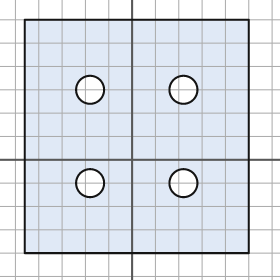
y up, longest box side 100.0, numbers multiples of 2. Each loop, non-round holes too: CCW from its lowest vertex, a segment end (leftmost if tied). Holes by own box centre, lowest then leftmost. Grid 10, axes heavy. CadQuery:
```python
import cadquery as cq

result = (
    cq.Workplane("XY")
    .moveTo(-46.0, -40.0)
    .lineTo(50.0, -40.0)
    .lineTo(50.0, 60.0)
    .lineTo(-46.0, 60.0)
    .close()
    .moveTo(-18.0, -10.0)
    .circle(6.0)
    .moveTo(22.0, -10.0)
    .circle(6.0)
    .moveTo(-18.0, 30.0)
    .circle(6.0)
    .moveTo(22.0, 30.0)
    .circle(6.0)
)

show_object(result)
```